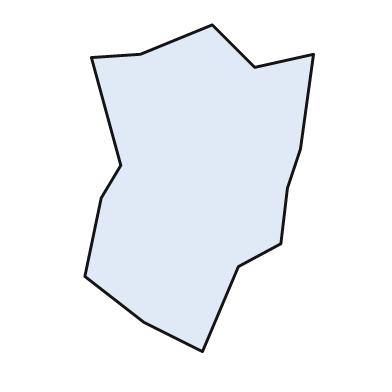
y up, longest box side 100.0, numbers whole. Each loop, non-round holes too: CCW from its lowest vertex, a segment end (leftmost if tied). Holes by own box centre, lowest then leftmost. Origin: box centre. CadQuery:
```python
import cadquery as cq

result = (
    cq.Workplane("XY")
    .moveTo(1.0, -50.0)
    .lineTo(12.0, -24.0)
    .lineTo(25.0, -17.0)
    .lineTo(27.0, 0.0)
    .lineTo(31.0, 12.0)
    .lineTo(35.0, 41.0)
    .lineTo(17.0, 37.0)
    .lineTo(4.0, 50.0)
    .lineTo(-18.0, 41.0)
    .lineTo(-33.0, 40.0)
    .lineTo(-24.0, 7.0)
    .lineTo(-30.0, -3.0)
    .lineTo(-35.0, -27.0)
    .lineTo(-17.0, -41.0)
    .close()
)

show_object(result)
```